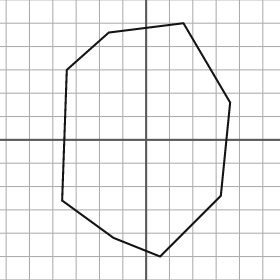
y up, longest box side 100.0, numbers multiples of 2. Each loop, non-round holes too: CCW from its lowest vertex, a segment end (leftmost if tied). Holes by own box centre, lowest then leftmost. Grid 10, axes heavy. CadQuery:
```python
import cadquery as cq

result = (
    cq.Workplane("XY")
    .moveTo(6.0, -50.0)
    .lineTo(32.0, -24.0)
    .lineTo(36.0, 16.0)
    .lineTo(16.0, 50.0)
    .lineTo(-16.0, 46.0)
    .lineTo(-34.0, 30.0)
    .lineTo(-36.0, -26.0)
    .lineTo(-14.0, -42.0)
    .close()
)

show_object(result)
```